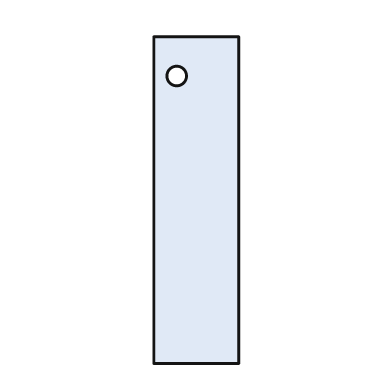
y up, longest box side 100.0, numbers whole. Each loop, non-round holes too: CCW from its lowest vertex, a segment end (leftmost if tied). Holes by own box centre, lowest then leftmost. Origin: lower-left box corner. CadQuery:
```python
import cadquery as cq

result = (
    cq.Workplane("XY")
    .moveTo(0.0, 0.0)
    .lineTo(26.0, 0.0)
    .lineTo(26.0, 100.0)
    .lineTo(0.0, 100.0)
    .close()
    .moveTo(7.0, 88.0)
    .circle(3.0)
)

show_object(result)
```